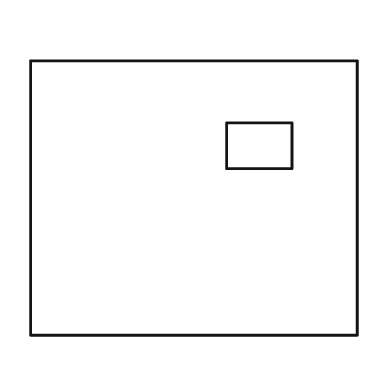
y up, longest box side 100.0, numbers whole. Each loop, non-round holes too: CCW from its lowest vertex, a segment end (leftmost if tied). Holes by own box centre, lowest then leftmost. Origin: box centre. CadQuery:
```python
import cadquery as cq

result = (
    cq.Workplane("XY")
    .moveTo(-50.0, -42.0)
    .lineTo(50.0, -42.0)
    .lineTo(50.0, 42.0)
    .lineTo(-50.0, 42.0)
    .close()
    .moveTo(10.0, 9.0)
    .lineTo(30.0, 9.0)
    .lineTo(30.0, 23.0)
    .lineTo(10.0, 23.0)
    .close()
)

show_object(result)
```